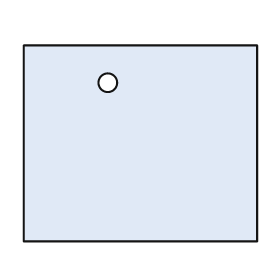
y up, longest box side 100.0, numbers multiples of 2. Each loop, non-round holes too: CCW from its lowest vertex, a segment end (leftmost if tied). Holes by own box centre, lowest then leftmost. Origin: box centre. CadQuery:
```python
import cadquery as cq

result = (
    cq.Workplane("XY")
    .moveTo(-50.0, -42.0)
    .lineTo(50.0, -42.0)
    .lineTo(50.0, 42.0)
    .lineTo(-50.0, 42.0)
    .close()
    .moveTo(-14.0, 26.0)
    .circle(4.0)
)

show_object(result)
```